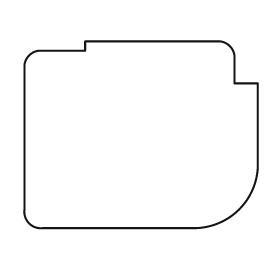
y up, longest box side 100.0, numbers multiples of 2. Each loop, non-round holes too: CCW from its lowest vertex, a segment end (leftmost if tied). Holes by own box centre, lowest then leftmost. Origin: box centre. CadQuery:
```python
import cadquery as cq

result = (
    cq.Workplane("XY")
    .moveTo(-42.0, -40.0)
    .lineTo(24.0, -40.0)
    .threePointArc((42.0, -32.0), (50.0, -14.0))
    .lineTo(50.0, 22.0)
    .lineTo(40.0, 22.0)
    .lineTo(40.0, 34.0)
    .threePointArc((38.0, 38.0), (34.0, 40.0))
    .lineTo(-24.0, 40.0)
    .lineTo(-24.0, 36.0)
    .lineTo(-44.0, 36.0)
    .threePointArc((-48.0, 34.0), (-50.0, 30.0))
    .lineTo(-50.0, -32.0)
    .threePointArc((-48.0, -38.0), (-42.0, -40.0))
    .close()
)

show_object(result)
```